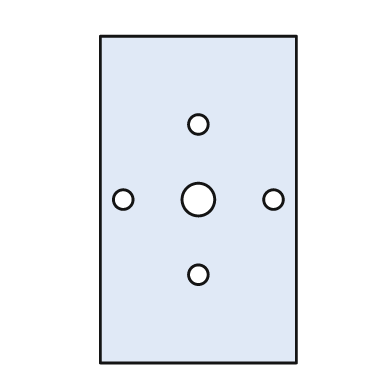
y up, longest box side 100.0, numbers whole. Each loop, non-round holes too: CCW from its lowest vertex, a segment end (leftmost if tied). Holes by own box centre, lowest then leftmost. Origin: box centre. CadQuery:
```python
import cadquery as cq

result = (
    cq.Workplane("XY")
    .moveTo(-30.0, -50.0)
    .lineTo(30.0, -50.0)
    .lineTo(30.0, 50.0)
    .lineTo(-30.0, 50.0)
    .close()
    .moveTo(0.0, -23.0)
    .circle(3.0)
    .moveTo(-23.0, 0.0)
    .circle(3.0)
    .moveTo(0.0, 0.0)
    .circle(5.0)
    .moveTo(23.0, 0.0)
    .circle(3.0)
    .moveTo(0.0, 23.0)
    .circle(3.0)
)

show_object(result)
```